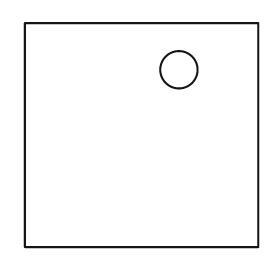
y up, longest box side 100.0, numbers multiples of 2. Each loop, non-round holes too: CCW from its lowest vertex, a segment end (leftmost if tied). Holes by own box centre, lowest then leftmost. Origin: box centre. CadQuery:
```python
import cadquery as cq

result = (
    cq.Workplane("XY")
    .moveTo(-50.0, -48.0)
    .lineTo(50.0, -48.0)
    .lineTo(50.0, 48.0)
    .lineTo(-50.0, 48.0)
    .close()
    .moveTo(16.0, 28.0)
    .circle(8.0)
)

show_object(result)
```